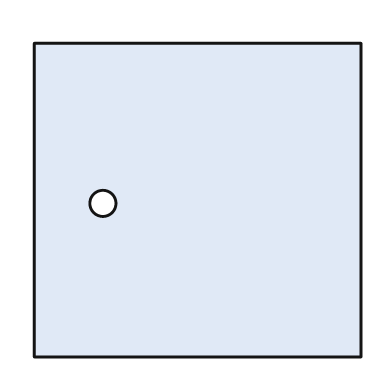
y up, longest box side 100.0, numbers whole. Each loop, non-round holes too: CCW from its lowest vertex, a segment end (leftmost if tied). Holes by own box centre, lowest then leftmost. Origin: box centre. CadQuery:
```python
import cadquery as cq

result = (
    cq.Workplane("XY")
    .moveTo(-50.0, -48.0)
    .lineTo(50.0, -48.0)
    .lineTo(50.0, 48.0)
    .lineTo(-50.0, 48.0)
    .close()
    .moveTo(-29.0, -1.0)
    .circle(4.0)
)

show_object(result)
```